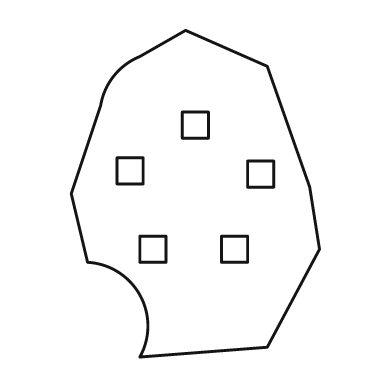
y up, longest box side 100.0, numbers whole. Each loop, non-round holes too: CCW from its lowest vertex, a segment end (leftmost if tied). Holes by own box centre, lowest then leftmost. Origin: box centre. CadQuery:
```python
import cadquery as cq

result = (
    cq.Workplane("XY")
    .moveTo(-17.0, -50.0)
    .lineTo(22.0, -47.0)
    .lineTo(38.0, -17.0)
    .lineTo(35.0, 2.0)
    .lineTo(22.0, 39.0)
    .lineTo(-3.0, 50.0)
    .lineTo(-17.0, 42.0)
    .threePointArc((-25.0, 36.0), (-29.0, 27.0))
    .lineTo(-38.0, 0.0)
    .lineTo(-33.0, -21.0)
    .threePointArc((-17.0, -31.0), (-17.0, -50.0))
    .close()
    .moveTo(-17.0, -21.0)
    .lineTo(-9.0, -21.0)
    .lineTo(-9.0, -13.0)
    .lineTo(-17.0, -13.0)
    .close()
    .moveTo(8.0, -21.0)
    .lineTo(16.0, -21.0)
    .lineTo(16.0, -13.0)
    .lineTo(8.0, -13.0)
    .close()
    .moveTo(16.0, 2.0)
    .lineTo(24.0, 2.0)
    .lineTo(24.0, 10.0)
    .lineTo(16.0, 10.0)
    .close()
    .moveTo(-24.0, 3.0)
    .lineTo(-16.0, 3.0)
    .lineTo(-16.0, 11.0)
    .lineTo(-24.0, 11.0)
    .close()
    .moveTo(-4.0, 17.0)
    .lineTo(4.0, 17.0)
    .lineTo(4.0, 25.0)
    .lineTo(-4.0, 25.0)
    .close()
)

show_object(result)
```